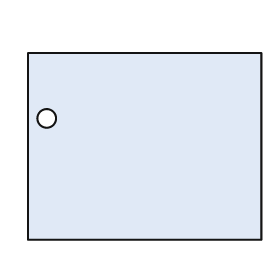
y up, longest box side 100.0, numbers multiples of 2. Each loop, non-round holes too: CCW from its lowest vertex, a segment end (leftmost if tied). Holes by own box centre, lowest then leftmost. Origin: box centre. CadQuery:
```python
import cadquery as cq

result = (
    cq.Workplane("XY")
    .moveTo(-50.0, -40.0)
    .lineTo(50.0, -40.0)
    .lineTo(50.0, 40.0)
    .lineTo(-50.0, 40.0)
    .close()
    .moveTo(-42.0, 12.0)
    .circle(4.0)
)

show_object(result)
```